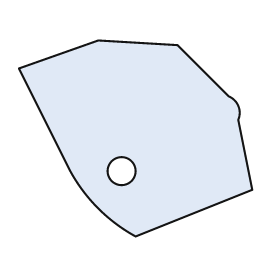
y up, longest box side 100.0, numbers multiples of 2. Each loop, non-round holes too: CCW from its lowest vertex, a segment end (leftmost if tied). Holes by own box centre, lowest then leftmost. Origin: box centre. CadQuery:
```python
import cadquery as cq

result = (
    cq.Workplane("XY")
    .moveTo(0.0, -42.0)
    .lineTo(50.0, -22.0)
    .lineTo(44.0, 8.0)
    .threePointArc((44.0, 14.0), (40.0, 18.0))
    .lineTo(18.0, 40.0)
    .lineTo(-16.0, 42.0)
    .lineTo(-50.0, 30.0)
    .lineTo(-28.0, -14.0)
    .threePointArc((-16.0, -30.0), (0.0, -42.0))
    .close()
    .moveTo(-6.0, -14.0)
    .circle(6.0)
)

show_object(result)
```